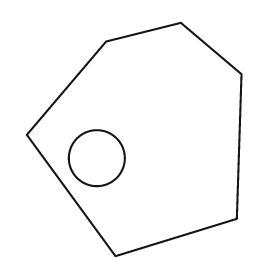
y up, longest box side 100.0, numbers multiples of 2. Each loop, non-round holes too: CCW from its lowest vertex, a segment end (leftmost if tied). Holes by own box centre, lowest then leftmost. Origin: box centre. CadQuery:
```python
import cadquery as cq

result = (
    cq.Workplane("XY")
    .moveTo(-8.0, -50.0)
    .lineTo(44.0, -34.0)
    .lineTo(46.0, 28.0)
    .lineTo(20.0, 50.0)
    .lineTo(-12.0, 42.0)
    .lineTo(-46.0, 2.0)
    .close()
    .moveTo(-16.0, -8.0)
    .circle(12.0)
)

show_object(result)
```